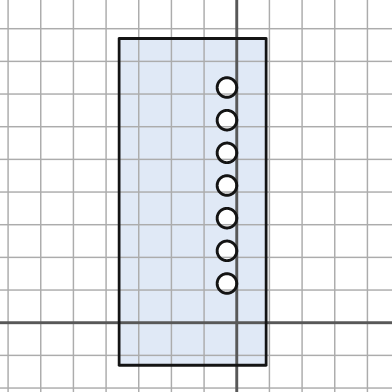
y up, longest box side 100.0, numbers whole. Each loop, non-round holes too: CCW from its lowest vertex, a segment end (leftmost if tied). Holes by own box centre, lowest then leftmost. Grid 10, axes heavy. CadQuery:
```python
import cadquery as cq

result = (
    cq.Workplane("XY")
    .moveTo(-36.0, -13.0)
    .lineTo(9.0, -13.0)
    .lineTo(9.0, 87.0)
    .lineTo(-36.0, 87.0)
    .close()
    .moveTo(-3.0, 12.0)
    .circle(3.0)
    .moveTo(-3.0, 22.0)
    .circle(3.0)
    .moveTo(-3.0, 32.0)
    .circle(3.0)
    .moveTo(-3.0, 42.0)
    .circle(3.0)
    .moveTo(-3.0, 52.0)
    .circle(3.0)
    .moveTo(-3.0, 62.0)
    .circle(3.0)
    .moveTo(-3.0, 72.0)
    .circle(3.0)
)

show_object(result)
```